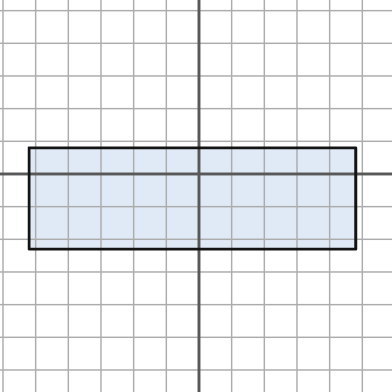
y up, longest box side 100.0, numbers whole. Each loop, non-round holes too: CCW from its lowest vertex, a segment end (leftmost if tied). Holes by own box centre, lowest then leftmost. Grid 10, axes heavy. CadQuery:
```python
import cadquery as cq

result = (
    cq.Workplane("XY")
    .moveTo(-52.0, -23.0)
    .lineTo(48.0, -23.0)
    .lineTo(48.0, 8.0)
    .lineTo(-52.0, 8.0)
    .close()
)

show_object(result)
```